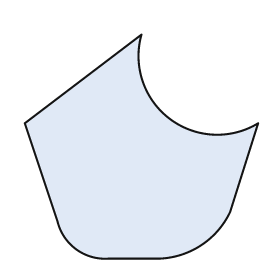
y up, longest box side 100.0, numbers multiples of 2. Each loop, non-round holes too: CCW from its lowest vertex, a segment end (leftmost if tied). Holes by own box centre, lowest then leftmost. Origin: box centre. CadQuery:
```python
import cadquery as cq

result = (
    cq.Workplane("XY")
    .moveTo(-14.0, -48.0)
    .lineTo(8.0, -48.0)
    .threePointArc((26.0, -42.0), (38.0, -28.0))
    .lineTo(50.0, 10.0)
    .threePointArc((12.0, 12.0), (0.0, 48.0))
    .lineTo(-50.0, 10.0)
    .lineTo(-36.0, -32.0)
    .threePointArc((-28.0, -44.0), (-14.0, -48.0))
    .close()
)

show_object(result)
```